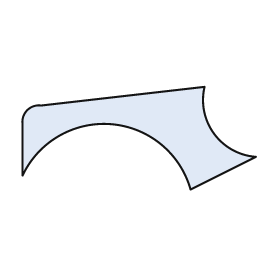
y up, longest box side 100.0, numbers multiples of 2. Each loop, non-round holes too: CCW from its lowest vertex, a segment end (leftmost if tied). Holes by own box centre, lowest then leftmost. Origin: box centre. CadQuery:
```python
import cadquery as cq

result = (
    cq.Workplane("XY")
    .moveTo(22.0, -22.0)
    .lineTo(50.0, -8.0)
    .threePointArc((32.0, 2.0), (28.0, 22.0))
    .lineTo(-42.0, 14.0)
    .threePointArc((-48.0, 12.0), (-50.0, 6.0))
    .lineTo(-50.0, -16.0)
    .threePointArc((-12.0, 6.0), (22.0, -22.0))
    .close()
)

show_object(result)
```